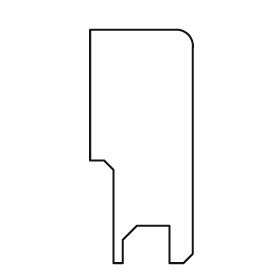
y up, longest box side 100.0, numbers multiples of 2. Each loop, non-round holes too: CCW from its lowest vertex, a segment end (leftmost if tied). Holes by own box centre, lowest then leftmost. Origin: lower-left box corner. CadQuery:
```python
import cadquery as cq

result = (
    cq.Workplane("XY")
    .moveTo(10.0, 0.0)
    .lineTo(14.0, 0.0)
    .lineTo(14.0, 10.0)
    .lineTo(20.0, 16.0)
    .lineTo(34.0, 16.0)
    .lineTo(34.0, 0.0)
    .lineTo(40.0, 0.0)
    .lineTo(44.0, 4.0)
    .lineTo(44.0, 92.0)
    .threePointArc((42.0, 98.0), (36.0, 100.0))
    .lineTo(0.0, 100.0)
    .lineTo(0.0, 44.0)
    .lineTo(6.0, 44.0)
    .lineTo(10.0, 40.0)
    .close()
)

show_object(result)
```